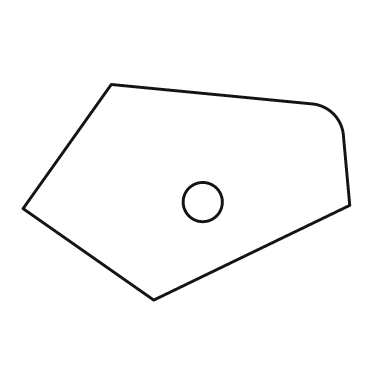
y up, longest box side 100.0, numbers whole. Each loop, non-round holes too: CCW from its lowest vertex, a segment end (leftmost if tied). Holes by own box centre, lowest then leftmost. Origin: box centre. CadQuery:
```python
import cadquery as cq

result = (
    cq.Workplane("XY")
    .moveTo(-10.0, -33.0)
    .lineTo(50.0, -4.0)
    .lineTo(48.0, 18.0)
    .threePointArc((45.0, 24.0), (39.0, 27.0))
    .lineTo(-23.0, 33.0)
    .lineTo(-50.0, -5.0)
    .close()
    .moveTo(5.0, -3.0)
    .circle(6.0)
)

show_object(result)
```